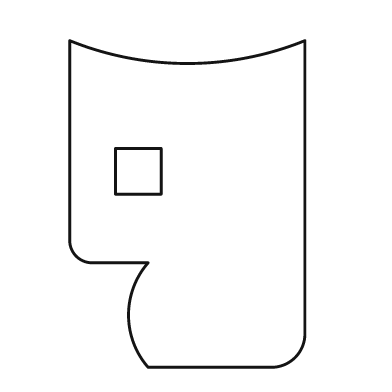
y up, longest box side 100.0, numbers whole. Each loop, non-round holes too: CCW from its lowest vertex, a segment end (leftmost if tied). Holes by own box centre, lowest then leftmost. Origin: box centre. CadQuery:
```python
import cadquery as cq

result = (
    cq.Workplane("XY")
    .moveTo(-12.0, -50.0)
    .lineTo(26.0, -50.0)
    .threePointArc((33.0, -47.0), (36.0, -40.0))
    .lineTo(36.0, 50.0)
    .threePointArc((0.0, 43.0), (-36.0, 50.0))
    .lineTo(-36.0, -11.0)
    .threePointArc((-34.0, -16.0), (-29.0, -18.0))
    .lineTo(-12.0, -18.0)
    .threePointArc((-18.0, -34.0), (-12.0, -50.0))
    .close()
    .moveTo(-22.0, 3.0)
    .lineTo(-8.0, 3.0)
    .lineTo(-8.0, 17.0)
    .lineTo(-22.0, 17.0)
    .close()
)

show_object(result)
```